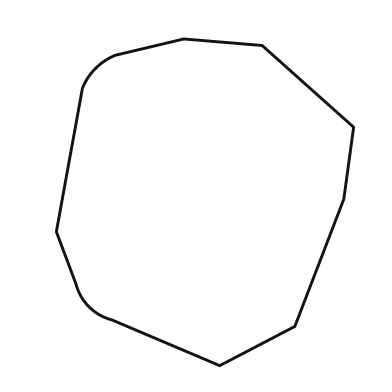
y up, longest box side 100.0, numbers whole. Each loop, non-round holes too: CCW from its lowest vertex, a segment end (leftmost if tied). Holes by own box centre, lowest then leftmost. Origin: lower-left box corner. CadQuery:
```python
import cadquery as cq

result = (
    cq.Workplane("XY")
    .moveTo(50.0, 0.0)
    .lineTo(73.0, 12.0)
    .lineTo(88.0, 51.0)
    .lineTo(91.0, 73.0)
    .lineTo(63.0, 98.0)
    .lineTo(39.0, 100.0)
    .lineTo(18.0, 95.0)
    .threePointArc((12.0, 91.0), (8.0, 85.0))
    .lineTo(0.0, 41.0)
    .lineTo(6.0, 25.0)
    .threePointArc((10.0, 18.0), (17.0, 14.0))
    .close()
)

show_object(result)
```